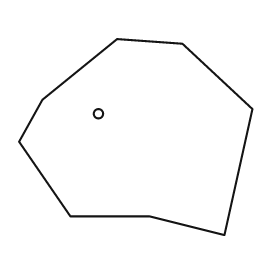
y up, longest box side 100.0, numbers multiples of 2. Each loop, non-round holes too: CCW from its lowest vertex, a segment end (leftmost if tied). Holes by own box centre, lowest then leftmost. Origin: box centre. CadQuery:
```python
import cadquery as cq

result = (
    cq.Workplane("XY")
    .moveTo(38.0, -42.0)
    .lineTo(50.0, 12.0)
    .lineTo(20.0, 40.0)
    .lineTo(-8.0, 42.0)
    .lineTo(-40.0, 16.0)
    .lineTo(-50.0, -2.0)
    .lineTo(-28.0, -34.0)
    .lineTo(6.0, -34.0)
    .close()
    .moveTo(-16.0, 10.0)
    .circle(2.0)
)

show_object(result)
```